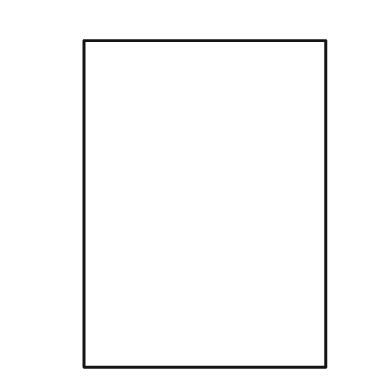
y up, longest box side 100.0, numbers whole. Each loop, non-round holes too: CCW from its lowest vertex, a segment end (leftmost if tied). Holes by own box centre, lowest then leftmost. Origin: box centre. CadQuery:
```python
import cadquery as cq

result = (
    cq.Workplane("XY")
    .moveTo(-37.0, -50.0)
    .lineTo(37.0, -50.0)
    .lineTo(37.0, 50.0)
    .lineTo(-37.0, 50.0)
    .close()
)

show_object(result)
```